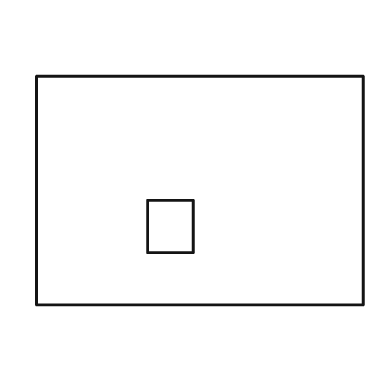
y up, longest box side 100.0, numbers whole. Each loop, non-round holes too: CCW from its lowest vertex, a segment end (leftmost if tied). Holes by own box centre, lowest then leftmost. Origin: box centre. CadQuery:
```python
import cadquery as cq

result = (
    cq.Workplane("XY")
    .moveTo(-50.0, -35.0)
    .lineTo(50.0, -35.0)
    .lineTo(50.0, 35.0)
    .lineTo(-50.0, 35.0)
    .close()
    .moveTo(-16.0, -19.0)
    .lineTo(-2.0, -19.0)
    .lineTo(-2.0, -3.0)
    .lineTo(-16.0, -3.0)
    .close()
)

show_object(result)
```